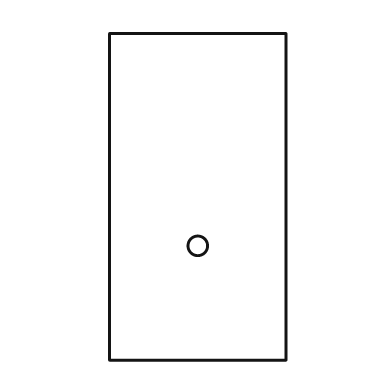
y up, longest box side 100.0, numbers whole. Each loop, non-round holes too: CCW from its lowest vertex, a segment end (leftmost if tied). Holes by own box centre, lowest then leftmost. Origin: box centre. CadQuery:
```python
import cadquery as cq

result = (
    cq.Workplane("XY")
    .moveTo(-27.0, -50.0)
    .lineTo(27.0, -50.0)
    .lineTo(27.0, 50.0)
    .lineTo(-27.0, 50.0)
    .close()
    .moveTo(0.0, -15.0)
    .circle(3.0)
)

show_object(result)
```